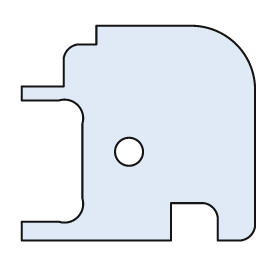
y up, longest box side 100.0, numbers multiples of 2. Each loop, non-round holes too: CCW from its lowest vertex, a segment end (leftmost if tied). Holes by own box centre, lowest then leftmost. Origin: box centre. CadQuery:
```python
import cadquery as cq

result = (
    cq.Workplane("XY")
    .moveTo(-50.0, -46.0)
    .lineTo(14.0, -46.0)
    .lineTo(14.0, -30.0)
    .lineTo(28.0, -30.0)
    .threePointArc((32.0, -32.0), (34.0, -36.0))
    .lineTo(34.0, -46.0)
    .lineTo(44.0, -46.0)
    .threePointArc((48.0, -44.0), (50.0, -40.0))
    .lineTo(50.0, 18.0)
    .threePointArc((42.0, 38.0), (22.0, 46.0))
    .lineTo(-18.0, 46.0)
    .lineTo(-18.0, 38.0)
    .lineTo(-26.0, 38.0)
    .threePointArc((-30.0, 36.0), (-32.0, 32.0))
    .lineTo(-32.0, 20.0)
    .lineTo(-50.0, 20.0)
    .lineTo(-50.0, 14.0)
    .lineTo(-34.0, 14.0)
    .threePointArc((-26.0, 12.0), (-24.0, 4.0))
    .lineTo(-24.0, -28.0)
    .threePointArc((-26.0, -36.0), (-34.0, -38.0))
    .lineTo(-50.0, -38.0)
    .close()
    .moveTo(-4.0, -8.0)
    .circle(6.0)
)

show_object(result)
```